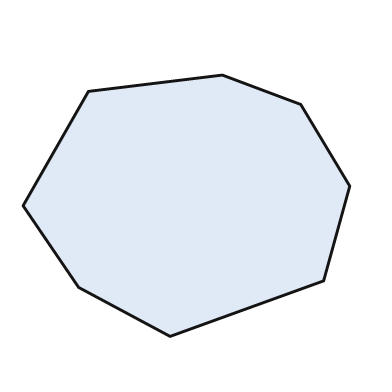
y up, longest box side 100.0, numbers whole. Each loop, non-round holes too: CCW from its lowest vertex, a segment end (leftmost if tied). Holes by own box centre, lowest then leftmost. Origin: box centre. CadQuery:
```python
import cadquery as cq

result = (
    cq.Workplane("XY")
    .moveTo(-5.0, -40.0)
    .lineTo(42.0, -23.0)
    .lineTo(50.0, 6.0)
    .lineTo(35.0, 31.0)
    .lineTo(11.0, 40.0)
    .lineTo(-30.0, 35.0)
    .lineTo(-50.0, 0.0)
    .lineTo(-33.0, -25.0)
    .close()
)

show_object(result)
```